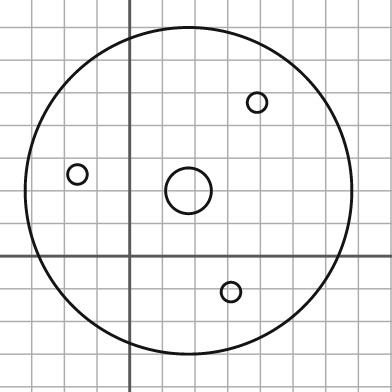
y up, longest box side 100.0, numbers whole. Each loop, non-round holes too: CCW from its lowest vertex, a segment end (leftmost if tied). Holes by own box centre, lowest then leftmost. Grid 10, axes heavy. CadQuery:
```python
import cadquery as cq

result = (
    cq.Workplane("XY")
    .moveTo(18.0, 20.0)
    .circle(50.0)
    .moveTo(31.0, -11.0)
    .circle(3.0)
    .moveTo(18.0, 20.0)
    .circle(7.0)
    .moveTo(-16.0, 25.0)
    .circle(3.0)
    .moveTo(39.0, 47.0)
    .circle(3.0)
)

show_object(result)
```